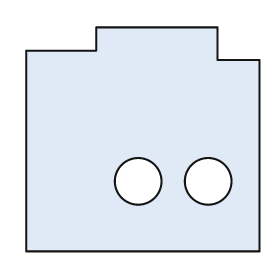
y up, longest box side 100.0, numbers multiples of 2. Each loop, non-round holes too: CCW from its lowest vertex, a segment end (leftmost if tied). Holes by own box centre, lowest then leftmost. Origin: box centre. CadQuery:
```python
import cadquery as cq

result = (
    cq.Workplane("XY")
    .moveTo(-50.0, -48.0)
    .lineTo(50.0, -48.0)
    .lineTo(50.0, 34.0)
    .lineTo(32.0, 34.0)
    .lineTo(32.0, 48.0)
    .lineTo(-20.0, 48.0)
    .lineTo(-20.0, 38.0)
    .lineTo(-50.0, 38.0)
    .close()
    .moveTo(-2.0, -18.0)
    .circle(10.0)
    .moveTo(28.0, -18.0)
    .circle(10.0)
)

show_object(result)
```